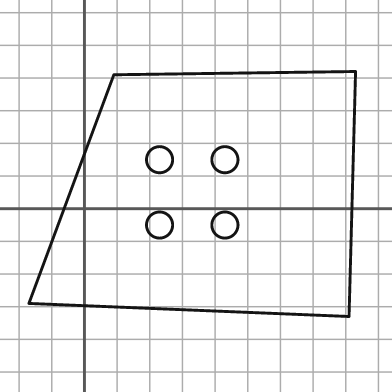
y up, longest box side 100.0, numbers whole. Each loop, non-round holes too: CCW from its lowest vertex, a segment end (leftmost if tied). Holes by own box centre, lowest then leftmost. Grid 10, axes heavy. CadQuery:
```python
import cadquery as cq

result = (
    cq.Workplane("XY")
    .moveTo(81.0, -33.0)
    .lineTo(83.0, 42.0)
    .lineTo(9.0, 41.0)
    .lineTo(-17.0, -29.0)
    .close()
    .moveTo(23.0, -5.0)
    .circle(4.0)
    .moveTo(43.0, -5.0)
    .circle(4.0)
    .moveTo(23.0, 15.0)
    .circle(4.0)
    .moveTo(43.0, 15.0)
    .circle(4.0)
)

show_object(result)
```